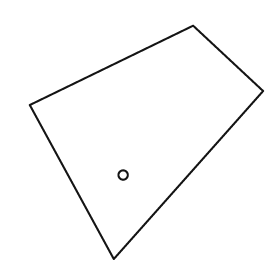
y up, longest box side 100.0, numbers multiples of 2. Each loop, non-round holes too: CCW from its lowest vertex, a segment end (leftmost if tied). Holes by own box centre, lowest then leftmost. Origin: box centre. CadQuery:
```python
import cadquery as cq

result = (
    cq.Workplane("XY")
    .moveTo(-14.0, -50.0)
    .lineTo(50.0, 22.0)
    .lineTo(20.0, 50.0)
    .lineTo(-50.0, 16.0)
    .close()
    .moveTo(-10.0, -14.0)
    .circle(2.0)
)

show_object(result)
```